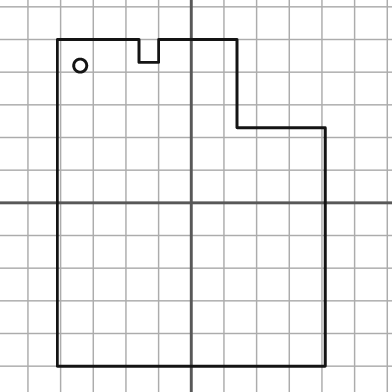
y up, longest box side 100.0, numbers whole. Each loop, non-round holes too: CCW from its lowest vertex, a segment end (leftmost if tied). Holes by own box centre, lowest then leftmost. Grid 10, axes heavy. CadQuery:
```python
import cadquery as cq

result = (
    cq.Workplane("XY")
    .moveTo(-41.0, -50.0)
    .lineTo(41.0, -50.0)
    .lineTo(41.0, 23.0)
    .lineTo(14.0, 23.0)
    .lineTo(14.0, 50.0)
    .lineTo(-10.0, 50.0)
    .lineTo(-10.0, 43.0)
    .lineTo(-16.0, 43.0)
    .lineTo(-16.0, 50.0)
    .lineTo(-41.0, 50.0)
    .close()
    .moveTo(-34.0, 42.0)
    .circle(2.0)
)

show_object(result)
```